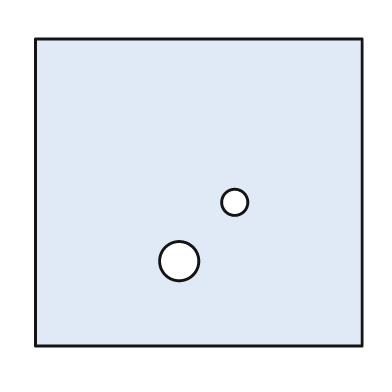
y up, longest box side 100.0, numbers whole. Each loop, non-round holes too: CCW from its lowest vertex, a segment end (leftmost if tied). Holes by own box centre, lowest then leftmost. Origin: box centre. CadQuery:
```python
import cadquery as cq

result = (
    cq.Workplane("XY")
    .moveTo(-50.0, -47.0)
    .lineTo(50.0, -47.0)
    .lineTo(50.0, 47.0)
    .lineTo(-50.0, 47.0)
    .close()
    .moveTo(-6.0, -21.0)
    .circle(6.0)
    .moveTo(11.0, -3.0)
    .circle(4.0)
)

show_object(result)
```